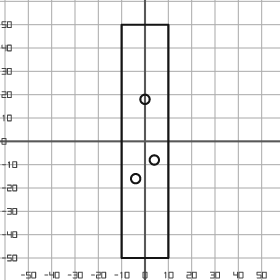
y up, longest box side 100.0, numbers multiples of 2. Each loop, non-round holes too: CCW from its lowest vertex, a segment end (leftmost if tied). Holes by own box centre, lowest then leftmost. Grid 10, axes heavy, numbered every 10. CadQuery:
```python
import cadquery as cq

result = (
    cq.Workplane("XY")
    .moveTo(-10.0, -50.0)
    .lineTo(10.0, -50.0)
    .lineTo(10.0, 50.0)
    .lineTo(-10.0, 50.0)
    .close()
    .moveTo(-4.0, -16.0)
    .circle(2.0)
    .moveTo(4.0, -8.0)
    .circle(2.0)
    .moveTo(0.0, 18.0)
    .circle(2.0)
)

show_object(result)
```